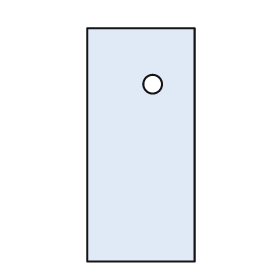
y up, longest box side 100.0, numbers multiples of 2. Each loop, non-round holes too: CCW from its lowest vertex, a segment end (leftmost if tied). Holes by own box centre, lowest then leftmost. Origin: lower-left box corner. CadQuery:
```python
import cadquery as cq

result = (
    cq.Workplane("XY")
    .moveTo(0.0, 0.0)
    .lineTo(46.0, 0.0)
    .lineTo(46.0, 100.0)
    .lineTo(0.0, 100.0)
    .close()
    .moveTo(28.0, 76.0)
    .circle(4.0)
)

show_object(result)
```